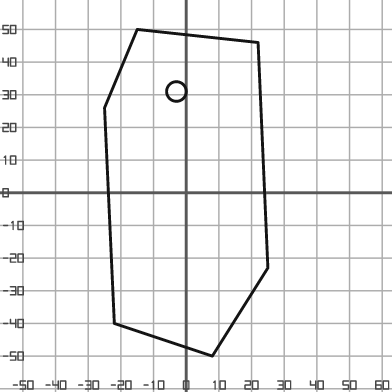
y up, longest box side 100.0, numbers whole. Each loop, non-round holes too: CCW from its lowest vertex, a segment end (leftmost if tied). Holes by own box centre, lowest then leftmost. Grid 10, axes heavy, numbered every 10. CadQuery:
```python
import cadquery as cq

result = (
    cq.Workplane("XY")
    .moveTo(8.0, -50.0)
    .lineTo(25.0, -23.0)
    .lineTo(22.0, 46.0)
    .lineTo(-15.0, 50.0)
    .lineTo(-25.0, 26.0)
    .lineTo(-22.0, -40.0)
    .close()
    .moveTo(-3.0, 31.0)
    .circle(3.0)
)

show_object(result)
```